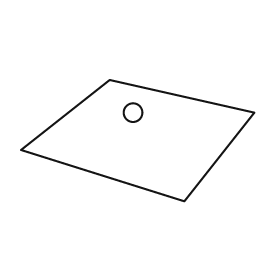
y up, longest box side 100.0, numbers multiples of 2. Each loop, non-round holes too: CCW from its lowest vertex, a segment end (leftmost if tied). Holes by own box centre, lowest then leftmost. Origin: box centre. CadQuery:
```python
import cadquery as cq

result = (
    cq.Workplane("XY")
    .moveTo(20.0, -26.0)
    .lineTo(50.0, 12.0)
    .lineTo(-12.0, 26.0)
    .lineTo(-50.0, -4.0)
    .close()
    .moveTo(-2.0, 12.0)
    .circle(4.0)
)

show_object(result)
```